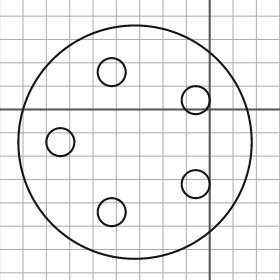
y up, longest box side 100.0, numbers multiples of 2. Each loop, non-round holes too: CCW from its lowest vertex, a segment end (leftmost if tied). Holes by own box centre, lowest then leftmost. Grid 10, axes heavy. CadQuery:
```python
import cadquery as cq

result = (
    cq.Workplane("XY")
    .moveTo(-32.0, -14.0)
    .circle(50.0)
    .moveTo(-42.0, -44.0)
    .circle(6.0)
    .moveTo(-6.0, -32.0)
    .circle(6.0)
    .moveTo(-64.0, -14.0)
    .circle(6.0)
    .moveTo(-6.0, 4.0)
    .circle(6.0)
    .moveTo(-42.0, 16.0)
    .circle(6.0)
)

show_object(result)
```